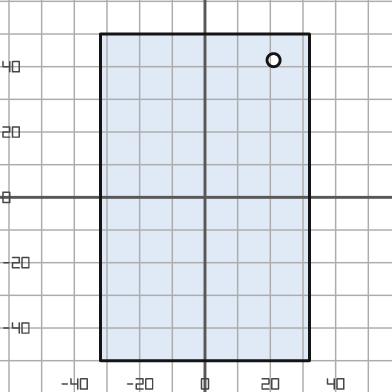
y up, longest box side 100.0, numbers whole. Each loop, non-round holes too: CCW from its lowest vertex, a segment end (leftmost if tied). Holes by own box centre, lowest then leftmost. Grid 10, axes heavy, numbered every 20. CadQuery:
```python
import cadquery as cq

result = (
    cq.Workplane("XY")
    .moveTo(-32.0, -50.0)
    .lineTo(32.0, -50.0)
    .lineTo(32.0, 50.0)
    .lineTo(-32.0, 50.0)
    .close()
    .moveTo(21.0, 42.0)
    .circle(2.0)
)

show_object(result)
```